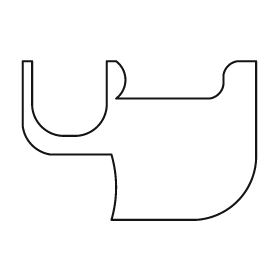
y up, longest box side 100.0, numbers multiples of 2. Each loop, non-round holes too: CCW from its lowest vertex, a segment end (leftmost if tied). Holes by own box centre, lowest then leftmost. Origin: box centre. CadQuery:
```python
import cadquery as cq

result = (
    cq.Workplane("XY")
    .moveTo(-12.0, -34.0)
    .lineTo(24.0, -34.0)
    .threePointArc((42.0, -26.0), (50.0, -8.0))
    .lineTo(50.0, 34.0)
    .lineTo(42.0, 34.0)
    .threePointArc((38.0, 32.0), (36.0, 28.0))
    .lineTo(36.0, 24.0)
    .threePointArc((34.0, 20.0), (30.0, 18.0))
    .lineTo(-10.0, 18.0)
    .threePointArc((-6.0, 26.0), (-10.0, 34.0))
    .lineTo(-14.0, 34.0)
    .lineTo(-14.0, 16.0)
    .threePointArc((-18.0, 6.0), (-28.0, 2.0))
    .lineTo(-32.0, 2.0)
    .threePointArc((-42.0, 6.0), (-46.0, 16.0))
    .lineTo(-46.0, 34.0)
    .lineTo(-50.0, 34.0)
    .lineTo(-50.0, 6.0)
    .threePointArc((-46.0, -2.0), (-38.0, -6.0))
    .lineTo(-12.0, -6.0)
    .threePointArc((-10.0, -20.0), (-12.0, -34.0))
    .close()
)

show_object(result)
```